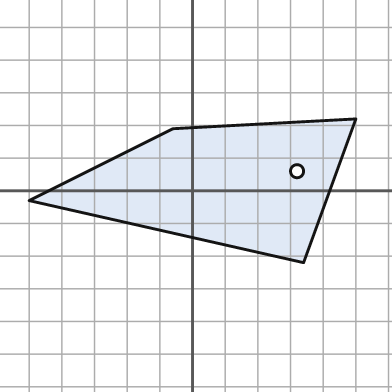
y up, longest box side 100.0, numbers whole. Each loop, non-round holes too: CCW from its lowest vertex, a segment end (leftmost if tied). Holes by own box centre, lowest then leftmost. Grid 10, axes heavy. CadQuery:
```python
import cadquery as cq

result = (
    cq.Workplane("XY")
    .moveTo(34.0, -22.0)
    .lineTo(50.0, 22.0)
    .lineTo(-6.0, 19.0)
    .lineTo(-50.0, -3.0)
    .close()
    .moveTo(32.0, 6.0)
    .circle(2.0)
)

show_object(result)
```